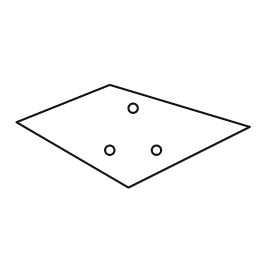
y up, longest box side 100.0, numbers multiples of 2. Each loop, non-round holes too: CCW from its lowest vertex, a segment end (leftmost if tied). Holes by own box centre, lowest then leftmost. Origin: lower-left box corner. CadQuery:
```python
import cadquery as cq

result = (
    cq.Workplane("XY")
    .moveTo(48.0, 0.0)
    .lineTo(100.0, 26.0)
    .lineTo(40.0, 44.0)
    .lineTo(0.0, 28.0)
    .close()
    .moveTo(40.0, 16.0)
    .circle(2.0)
    .moveTo(60.0, 16.0)
    .circle(2.0)
    .moveTo(50.0, 34.0)
    .circle(2.0)
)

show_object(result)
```